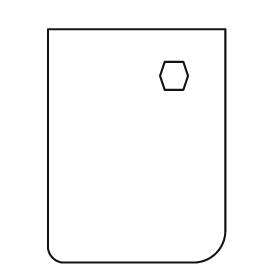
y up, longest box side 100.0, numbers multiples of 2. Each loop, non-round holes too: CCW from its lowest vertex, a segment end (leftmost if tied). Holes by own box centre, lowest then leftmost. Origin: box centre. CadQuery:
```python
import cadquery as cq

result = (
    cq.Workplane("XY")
    .moveTo(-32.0, -50.0)
    .lineTo(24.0, -50.0)
    .threePointArc((34.0, -46.0), (38.0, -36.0))
    .lineTo(38.0, 50.0)
    .lineTo(-38.0, 50.0)
    .lineTo(-38.0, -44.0)
    .threePointArc((-36.0, -48.0), (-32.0, -50.0))
    .close()
    .moveTo(12.0, 24.0)
    .lineTo(20.0, 24.0)
    .lineTo(22.0, 30.0)
    .lineTo(20.0, 36.0)
    .lineTo(12.0, 36.0)
    .lineTo(10.0, 30.0)
    .close()
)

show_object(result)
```